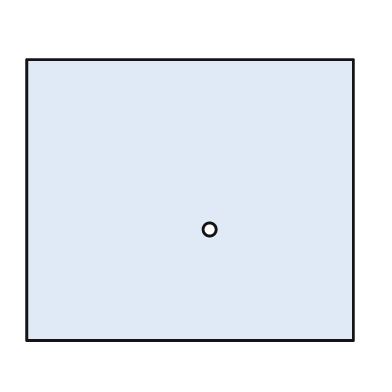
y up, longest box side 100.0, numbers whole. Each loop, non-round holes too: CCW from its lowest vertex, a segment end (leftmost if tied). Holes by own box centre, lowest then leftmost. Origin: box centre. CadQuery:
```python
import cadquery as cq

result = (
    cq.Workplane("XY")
    .moveTo(-50.0, -43.0)
    .lineTo(50.0, -43.0)
    .lineTo(50.0, 43.0)
    .lineTo(-50.0, 43.0)
    .close()
    .moveTo(6.0, -9.0)
    .circle(2.0)
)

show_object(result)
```